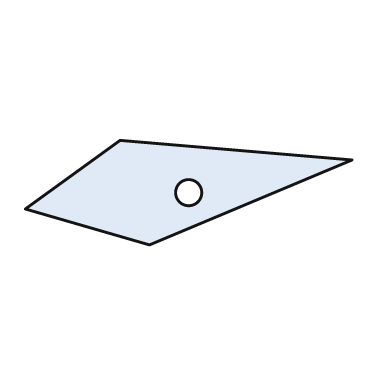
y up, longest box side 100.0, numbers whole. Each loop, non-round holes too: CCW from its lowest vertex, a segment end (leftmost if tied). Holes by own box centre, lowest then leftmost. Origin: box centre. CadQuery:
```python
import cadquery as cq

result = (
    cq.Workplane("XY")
    .moveTo(-12.0, -16.0)
    .lineTo(50.0, 10.0)
    .lineTo(-21.0, 16.0)
    .lineTo(-50.0, -5.0)
    .close()
    .moveTo(0.0, 0.0)
    .circle(4.0)
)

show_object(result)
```